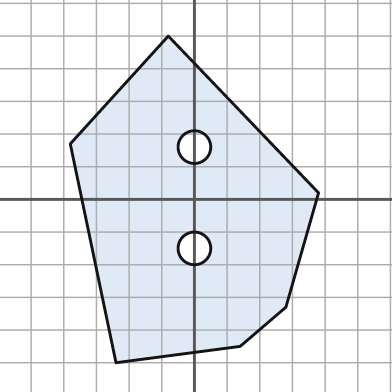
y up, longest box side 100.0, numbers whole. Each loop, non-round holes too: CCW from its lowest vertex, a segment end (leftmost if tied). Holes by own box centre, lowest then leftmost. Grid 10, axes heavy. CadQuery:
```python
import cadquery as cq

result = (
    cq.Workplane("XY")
    .moveTo(-24.0, -50.0)
    .lineTo(14.0, -45.0)
    .lineTo(28.0, -33.0)
    .lineTo(38.0, 2.0)
    .lineTo(-8.0, 50.0)
    .lineTo(-38.0, 17.0)
    .close()
    .moveTo(0.0, -15.0)
    .circle(5.0)
    .moveTo(0.0, 16.0)
    .circle(5.0)
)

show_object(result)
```